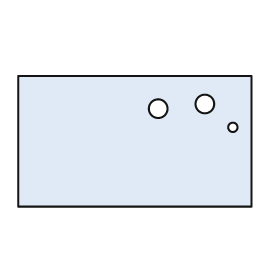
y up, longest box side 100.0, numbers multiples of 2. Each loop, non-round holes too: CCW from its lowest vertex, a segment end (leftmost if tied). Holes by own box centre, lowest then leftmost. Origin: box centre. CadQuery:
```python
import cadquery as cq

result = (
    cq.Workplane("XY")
    .moveTo(-50.0, -28.0)
    .lineTo(50.0, -28.0)
    .lineTo(50.0, 28.0)
    .lineTo(-50.0, 28.0)
    .close()
    .moveTo(42.0, 6.0)
    .circle(2.0)
    .moveTo(10.0, 14.0)
    .circle(4.0)
    .moveTo(30.0, 16.0)
    .circle(4.0)
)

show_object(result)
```